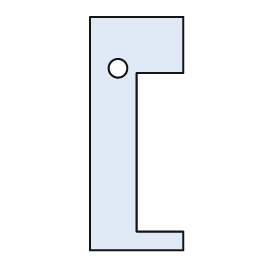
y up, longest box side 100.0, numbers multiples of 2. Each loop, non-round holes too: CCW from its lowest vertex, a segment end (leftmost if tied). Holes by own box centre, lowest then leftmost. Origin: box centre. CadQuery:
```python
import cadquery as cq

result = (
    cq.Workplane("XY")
    .moveTo(-20.0, -50.0)
    .lineTo(20.0, -50.0)
    .lineTo(20.0, -42.0)
    .lineTo(0.0, -42.0)
    .lineTo(0.0, 26.0)
    .lineTo(20.0, 26.0)
    .lineTo(20.0, 50.0)
    .lineTo(-20.0, 50.0)
    .close()
    .moveTo(-8.0, 28.0)
    .circle(4.0)
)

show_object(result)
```